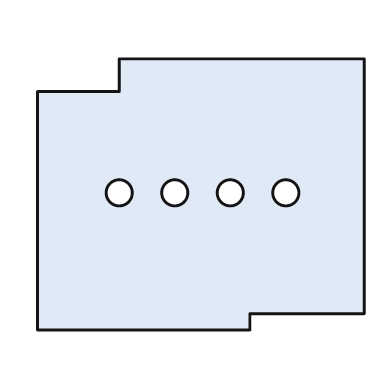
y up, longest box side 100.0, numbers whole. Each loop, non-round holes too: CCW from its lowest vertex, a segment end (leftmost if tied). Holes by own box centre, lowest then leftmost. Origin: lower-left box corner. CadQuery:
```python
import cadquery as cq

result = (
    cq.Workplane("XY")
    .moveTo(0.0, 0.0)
    .lineTo(65.0, 0.0)
    .lineTo(65.0, 5.0)
    .lineTo(100.0, 5.0)
    .lineTo(100.0, 83.0)
    .lineTo(25.0, 83.0)
    .lineTo(25.0, 73.0)
    .lineTo(0.0, 73.0)
    .close()
    .moveTo(25.0, 42.0)
    .circle(4.0)
    .moveTo(42.0, 42.0)
    .circle(4.0)
    .moveTo(59.0, 42.0)
    .circle(4.0)
    .moveTo(76.0, 42.0)
    .circle(4.0)
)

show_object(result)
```